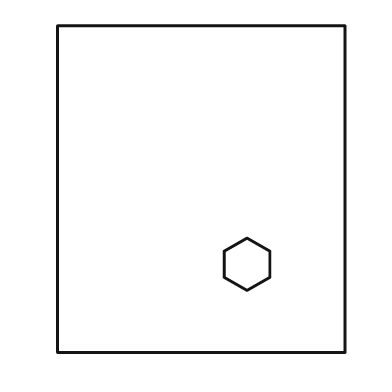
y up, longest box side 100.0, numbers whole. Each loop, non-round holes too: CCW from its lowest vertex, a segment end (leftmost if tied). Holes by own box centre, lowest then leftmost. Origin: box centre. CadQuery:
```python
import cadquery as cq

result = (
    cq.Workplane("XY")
    .moveTo(-44.0, -50.0)
    .lineTo(44.0, -50.0)
    .lineTo(44.0, 50.0)
    .lineTo(-44.0, 50.0)
    .close()
    .moveTo(14.0, -31.0)
    .lineTo(21.0, -27.0)
    .lineTo(21.0, -19.0)
    .lineTo(14.0, -15.0)
    .lineTo(7.0, -19.0)
    .lineTo(7.0, -27.0)
    .close()
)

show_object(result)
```